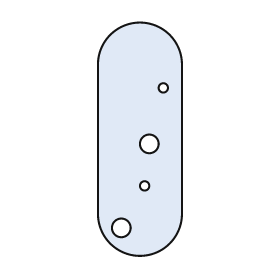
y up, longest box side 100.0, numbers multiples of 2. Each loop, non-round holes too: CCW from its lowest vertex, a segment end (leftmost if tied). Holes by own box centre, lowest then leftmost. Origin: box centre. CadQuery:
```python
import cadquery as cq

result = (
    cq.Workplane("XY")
    .moveTo(-18.0, -32.0)
    .threePointArc((0.0, -50.0), (18.0, -32.0))
    .lineTo(18.0, 32.0)
    .threePointArc((0.0, 50.0), (-18.0, 32.0))
    .close()
    .moveTo(-8.0, -38.0)
    .circle(4.0)
    .moveTo(2.0, -20.0)
    .circle(2.0)
    .moveTo(4.0, -2.0)
    .circle(4.0)
    .moveTo(10.0, 22.0)
    .circle(2.0)
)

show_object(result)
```